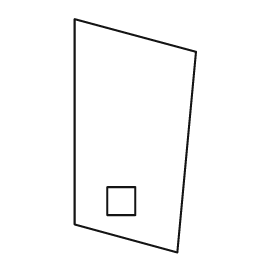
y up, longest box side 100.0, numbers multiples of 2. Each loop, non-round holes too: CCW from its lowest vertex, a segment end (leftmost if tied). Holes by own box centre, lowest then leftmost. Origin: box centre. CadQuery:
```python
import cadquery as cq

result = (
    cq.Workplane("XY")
    .moveTo(18.0, -50.0)
    .lineTo(26.0, 36.0)
    .lineTo(-26.0, 50.0)
    .lineTo(-26.0, -38.0)
    .close()
    .moveTo(-12.0, -34.0)
    .lineTo(0.0, -34.0)
    .lineTo(0.0, -22.0)
    .lineTo(-12.0, -22.0)
    .close()
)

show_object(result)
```